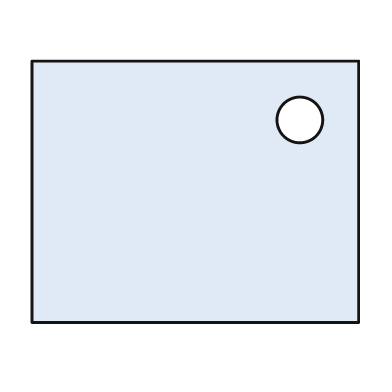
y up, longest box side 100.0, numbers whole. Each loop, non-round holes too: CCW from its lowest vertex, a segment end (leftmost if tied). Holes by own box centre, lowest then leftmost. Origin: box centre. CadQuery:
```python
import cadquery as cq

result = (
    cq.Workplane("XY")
    .moveTo(-50.0, -40.0)
    .lineTo(50.0, -40.0)
    .lineTo(50.0, 40.0)
    .lineTo(-50.0, 40.0)
    .close()
    .moveTo(32.0, 22.0)
    .circle(7.0)
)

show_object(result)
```